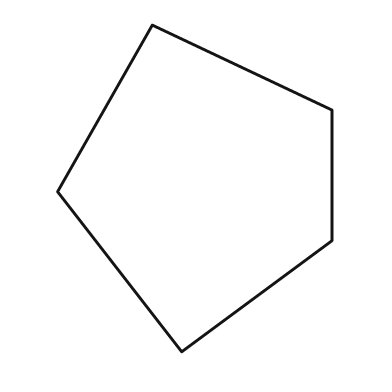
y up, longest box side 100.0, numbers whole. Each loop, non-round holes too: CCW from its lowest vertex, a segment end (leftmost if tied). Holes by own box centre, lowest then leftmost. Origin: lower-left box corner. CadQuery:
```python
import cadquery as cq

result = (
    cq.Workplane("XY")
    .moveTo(38.0, 0.0)
    .lineTo(84.0, 34.0)
    .lineTo(84.0, 74.0)
    .lineTo(29.0, 100.0)
    .lineTo(0.0, 49.0)
    .close()
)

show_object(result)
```